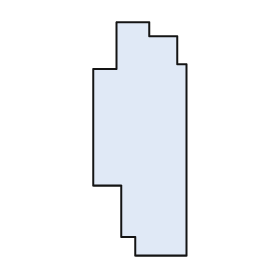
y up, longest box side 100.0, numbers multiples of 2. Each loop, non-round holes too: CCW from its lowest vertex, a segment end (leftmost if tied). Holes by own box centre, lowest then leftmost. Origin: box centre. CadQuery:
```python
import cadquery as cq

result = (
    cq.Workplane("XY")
    .moveTo(-2.0, -50.0)
    .lineTo(20.0, -50.0)
    .lineTo(20.0, 32.0)
    .lineTo(16.0, 32.0)
    .lineTo(16.0, 44.0)
    .lineTo(4.0, 44.0)
    .lineTo(4.0, 50.0)
    .lineTo(-10.0, 50.0)
    .lineTo(-10.0, 30.0)
    .lineTo(-20.0, 30.0)
    .lineTo(-20.0, -20.0)
    .lineTo(-8.0, -20.0)
    .lineTo(-8.0, -42.0)
    .lineTo(-2.0, -42.0)
    .close()
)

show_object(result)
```